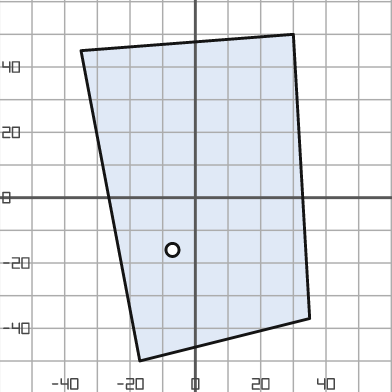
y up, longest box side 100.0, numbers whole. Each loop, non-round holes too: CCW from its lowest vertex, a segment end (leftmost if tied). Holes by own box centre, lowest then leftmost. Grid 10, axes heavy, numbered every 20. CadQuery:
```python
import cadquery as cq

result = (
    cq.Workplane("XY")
    .moveTo(-17.0, -50.0)
    .lineTo(35.0, -37.0)
    .lineTo(30.0, 50.0)
    .lineTo(-35.0, 45.0)
    .close()
    .moveTo(-7.0, -16.0)
    .circle(2.0)
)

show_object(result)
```